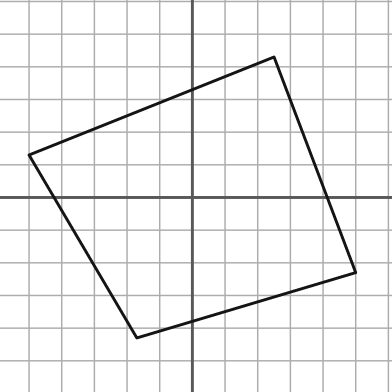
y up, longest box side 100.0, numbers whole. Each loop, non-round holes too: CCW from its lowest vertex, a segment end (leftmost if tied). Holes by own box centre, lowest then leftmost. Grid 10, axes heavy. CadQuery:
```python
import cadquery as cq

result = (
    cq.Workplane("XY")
    .moveTo(-17.0, -43.0)
    .lineTo(50.0, -23.0)
    .lineTo(25.0, 43.0)
    .lineTo(-50.0, 13.0)
    .close()
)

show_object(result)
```